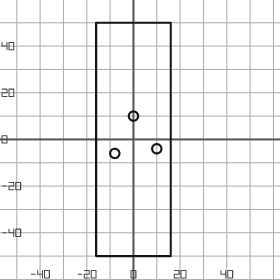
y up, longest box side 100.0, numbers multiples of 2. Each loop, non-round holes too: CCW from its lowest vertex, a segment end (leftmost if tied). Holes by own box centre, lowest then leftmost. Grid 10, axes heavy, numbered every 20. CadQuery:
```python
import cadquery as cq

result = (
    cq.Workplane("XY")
    .moveTo(-16.0, -50.0)
    .lineTo(16.0, -50.0)
    .lineTo(16.0, 50.0)
    .lineTo(-16.0, 50.0)
    .close()
    .moveTo(-8.0, -6.0)
    .circle(2.0)
    .moveTo(10.0, -4.0)
    .circle(2.0)
    .moveTo(0.0, 10.0)
    .circle(2.0)
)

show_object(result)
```